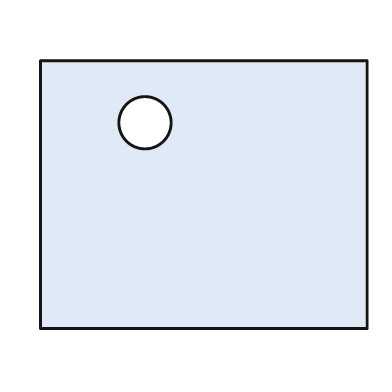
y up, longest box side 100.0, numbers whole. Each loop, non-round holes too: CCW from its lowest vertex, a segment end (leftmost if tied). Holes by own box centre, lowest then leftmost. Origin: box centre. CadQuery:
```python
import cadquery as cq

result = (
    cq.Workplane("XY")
    .moveTo(-50.0, -41.0)
    .lineTo(50.0, -41.0)
    .lineTo(50.0, 41.0)
    .lineTo(-50.0, 41.0)
    .close()
    .moveTo(-18.0, 22.0)
    .circle(8.0)
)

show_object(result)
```